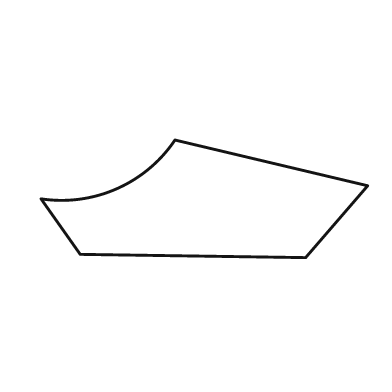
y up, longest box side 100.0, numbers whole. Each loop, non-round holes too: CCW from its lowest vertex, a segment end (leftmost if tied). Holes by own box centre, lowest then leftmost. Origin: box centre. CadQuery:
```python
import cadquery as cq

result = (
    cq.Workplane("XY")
    .moveTo(31.0, -18.0)
    .lineTo(50.0, 4.0)
    .lineTo(-9.0, 18.0)
    .threePointArc((-27.0, 3.0), (-50.0, 0.0))
    .lineTo(-38.0, -17.0)
    .close()
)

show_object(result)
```